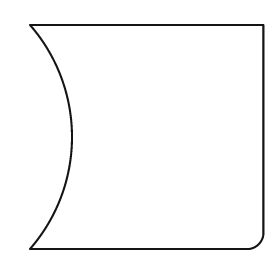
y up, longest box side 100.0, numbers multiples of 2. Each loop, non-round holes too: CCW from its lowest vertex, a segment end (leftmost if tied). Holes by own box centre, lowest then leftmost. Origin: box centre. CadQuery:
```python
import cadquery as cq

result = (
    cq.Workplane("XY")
    .moveTo(-50.0, -48.0)
    .lineTo(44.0, -48.0)
    .threePointArc((48.0, -46.0), (50.0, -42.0))
    .lineTo(50.0, 48.0)
    .lineTo(-50.0, 48.0)
    .threePointArc((-32.0, 0.0), (-50.0, -48.0))
    .close()
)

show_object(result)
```